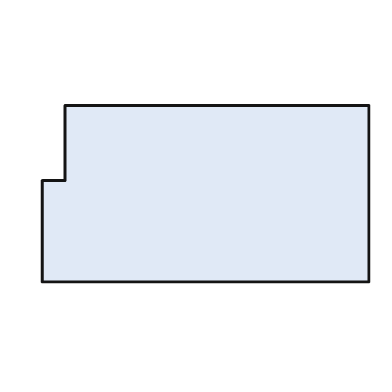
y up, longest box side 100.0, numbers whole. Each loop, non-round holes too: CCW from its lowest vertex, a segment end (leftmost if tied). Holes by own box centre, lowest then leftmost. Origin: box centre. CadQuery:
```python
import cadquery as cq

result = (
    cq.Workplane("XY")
    .moveTo(-50.0, -27.0)
    .lineTo(50.0, -27.0)
    .lineTo(50.0, 27.0)
    .lineTo(-43.0, 27.0)
    .lineTo(-43.0, 4.0)
    .lineTo(-50.0, 4.0)
    .close()
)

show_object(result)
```